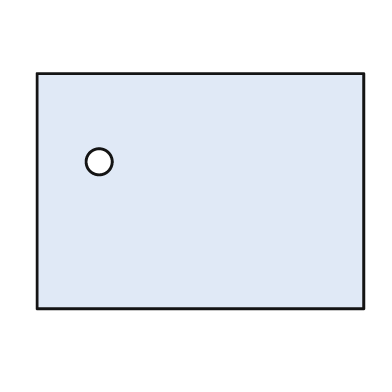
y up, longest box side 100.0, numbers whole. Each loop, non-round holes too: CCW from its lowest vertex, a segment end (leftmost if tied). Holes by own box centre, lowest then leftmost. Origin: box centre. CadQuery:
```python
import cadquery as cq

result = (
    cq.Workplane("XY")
    .moveTo(-50.0, -36.0)
    .lineTo(50.0, -36.0)
    .lineTo(50.0, 36.0)
    .lineTo(-50.0, 36.0)
    .close()
    .moveTo(-31.0, 9.0)
    .circle(4.0)
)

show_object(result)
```